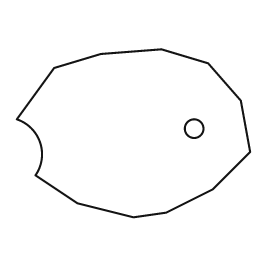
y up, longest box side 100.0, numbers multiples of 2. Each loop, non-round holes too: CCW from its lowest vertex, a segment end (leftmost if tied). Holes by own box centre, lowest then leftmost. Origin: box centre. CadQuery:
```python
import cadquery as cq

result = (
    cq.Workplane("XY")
    .moveTo(0.0, -36.0)
    .lineTo(14.0, -34.0)
    .lineTo(34.0, -24.0)
    .lineTo(50.0, -8.0)
    .lineTo(46.0, 14.0)
    .lineTo(32.0, 30.0)
    .lineTo(12.0, 36.0)
    .lineTo(-14.0, 34.0)
    .lineTo(-34.0, 28.0)
    .lineTo(-50.0, 6.0)
    .threePointArc((-40.0, -4.0), (-42.0, -18.0))
    .lineTo(-24.0, -30.0)
    .close()
    .moveTo(26.0, 2.0)
    .circle(4.0)
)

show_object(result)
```